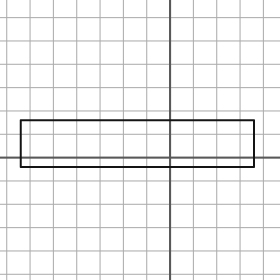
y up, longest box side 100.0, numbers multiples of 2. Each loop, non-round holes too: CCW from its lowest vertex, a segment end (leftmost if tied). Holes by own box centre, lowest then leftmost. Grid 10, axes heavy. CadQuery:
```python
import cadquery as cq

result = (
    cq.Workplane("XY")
    .moveTo(-64.0, -4.0)
    .lineTo(36.0, -4.0)
    .lineTo(36.0, 16.0)
    .lineTo(-64.0, 16.0)
    .close()
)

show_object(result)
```